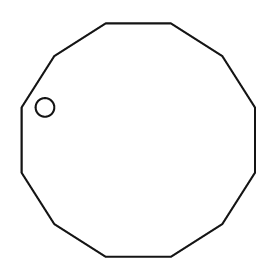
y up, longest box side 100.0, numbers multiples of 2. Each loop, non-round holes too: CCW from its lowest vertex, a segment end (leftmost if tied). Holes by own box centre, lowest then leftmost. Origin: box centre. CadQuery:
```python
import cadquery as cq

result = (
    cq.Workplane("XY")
    .moveTo(-14.0, -50.0)
    .lineTo(14.0, -50.0)
    .lineTo(36.0, -36.0)
    .lineTo(50.0, -14.0)
    .lineTo(50.0, 14.0)
    .lineTo(36.0, 36.0)
    .lineTo(14.0, 50.0)
    .lineTo(-14.0, 50.0)
    .lineTo(-36.0, 36.0)
    .lineTo(-50.0, 14.0)
    .lineTo(-50.0, -14.0)
    .lineTo(-36.0, -36.0)
    .close()
    .moveTo(-40.0, 14.0)
    .circle(4.0)
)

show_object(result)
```